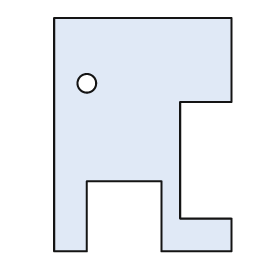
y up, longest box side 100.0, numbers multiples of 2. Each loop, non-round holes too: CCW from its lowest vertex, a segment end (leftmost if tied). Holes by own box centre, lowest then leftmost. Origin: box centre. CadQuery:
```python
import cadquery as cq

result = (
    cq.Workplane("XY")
    .moveTo(-38.0, -50.0)
    .lineTo(-24.0, -50.0)
    .lineTo(-24.0, -20.0)
    .lineTo(8.0, -20.0)
    .lineTo(8.0, -50.0)
    .lineTo(38.0, -50.0)
    .lineTo(38.0, -36.0)
    .lineTo(16.0, -36.0)
    .lineTo(16.0, 14.0)
    .lineTo(38.0, 14.0)
    .lineTo(38.0, 50.0)
    .lineTo(-38.0, 50.0)
    .close()
    .moveTo(-24.0, 22.0)
    .circle(4.0)
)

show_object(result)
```